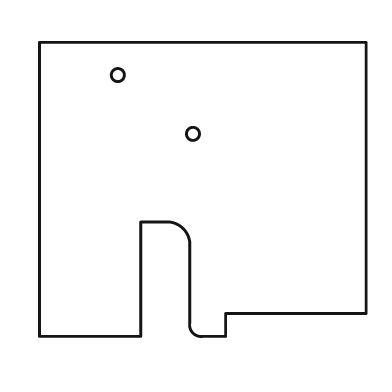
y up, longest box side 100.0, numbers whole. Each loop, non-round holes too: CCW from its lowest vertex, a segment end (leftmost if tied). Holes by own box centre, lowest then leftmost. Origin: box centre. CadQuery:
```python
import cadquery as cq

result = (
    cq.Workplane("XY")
    .moveTo(-50.0, -45.0)
    .lineTo(-19.0, -45.0)
    .lineTo(-19.0, -10.0)
    .lineTo(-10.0, -10.0)
    .threePointArc((-6.0, -12.0), (-4.0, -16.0))
    .lineTo(-4.0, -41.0)
    .threePointArc((-3.0, -44.0), (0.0, -45.0))
    .lineTo(7.0, -45.0)
    .lineTo(7.0, -38.0)
    .lineTo(50.0, -38.0)
    .lineTo(50.0, 45.0)
    .lineTo(-50.0, 45.0)
    .close()
    .moveTo(-3.0, 17.0)
    .circle(2.0)
    .moveTo(-26.0, 35.0)
    .circle(2.0)
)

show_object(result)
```